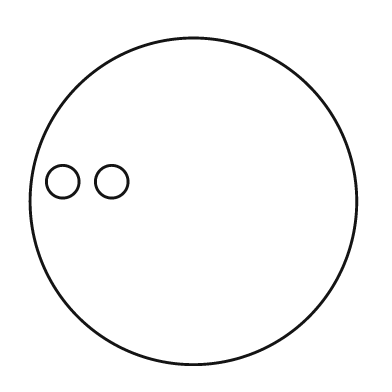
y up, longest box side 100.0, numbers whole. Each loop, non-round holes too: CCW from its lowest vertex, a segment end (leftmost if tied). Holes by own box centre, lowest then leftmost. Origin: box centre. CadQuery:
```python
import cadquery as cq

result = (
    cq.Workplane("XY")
    .moveTo(0.0, 0.0)
    .circle(50.0)
    .moveTo(-40.0, 6.0)
    .circle(5.0)
    .moveTo(-25.0, 6.0)
    .circle(5.0)
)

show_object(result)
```